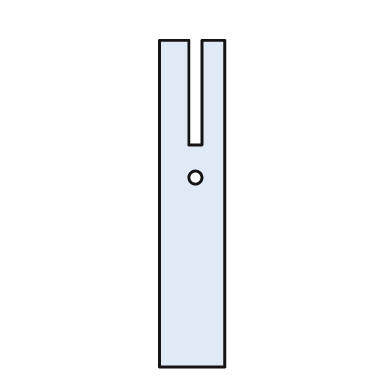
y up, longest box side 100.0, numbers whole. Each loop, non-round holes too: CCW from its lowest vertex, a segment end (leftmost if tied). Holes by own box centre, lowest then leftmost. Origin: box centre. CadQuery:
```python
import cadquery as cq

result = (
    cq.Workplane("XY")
    .moveTo(-10.0, -50.0)
    .lineTo(10.0, -50.0)
    .lineTo(10.0, 50.0)
    .lineTo(3.0, 50.0)
    .lineTo(3.0, 18.0)
    .lineTo(-1.0, 18.0)
    .lineTo(-1.0, 50.0)
    .lineTo(-10.0, 50.0)
    .close()
    .moveTo(1.0, 8.0)
    .circle(2.0)
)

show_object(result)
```